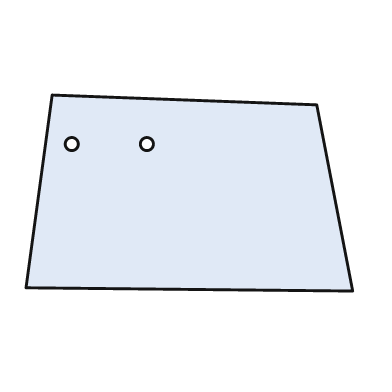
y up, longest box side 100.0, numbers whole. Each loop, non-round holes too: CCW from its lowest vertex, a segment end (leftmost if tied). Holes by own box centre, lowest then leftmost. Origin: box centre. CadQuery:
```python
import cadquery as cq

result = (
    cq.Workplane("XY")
    .moveTo(50.0, -30.0)
    .lineTo(39.0, 27.0)
    .lineTo(-42.0, 30.0)
    .lineTo(-50.0, -29.0)
    .close()
    .moveTo(-36.0, 15.0)
    .circle(2.0)
    .moveTo(-13.0, 15.0)
    .circle(2.0)
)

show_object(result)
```